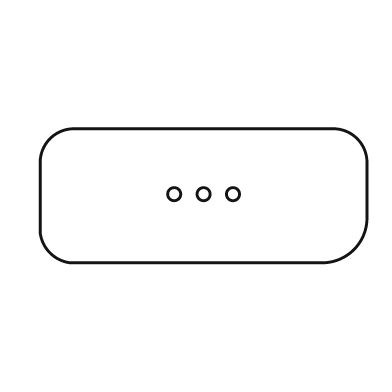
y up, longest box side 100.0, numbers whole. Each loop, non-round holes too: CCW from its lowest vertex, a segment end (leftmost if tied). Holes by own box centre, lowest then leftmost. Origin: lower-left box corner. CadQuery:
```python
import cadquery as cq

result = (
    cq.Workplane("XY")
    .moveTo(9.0, 0.0)
    .lineTo(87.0, 0.0)
    .threePointArc((96.0, 4.0), (100.0, 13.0))
    .lineTo(100.0, 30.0)
    .threePointArc((97.0, 38.0), (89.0, 41.0))
    .lineTo(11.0, 41.0)
    .threePointArc((3.0, 38.0), (0.0, 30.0))
    .lineTo(0.0, 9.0)
    .threePointArc((3.0, 3.0), (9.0, 0.0))
    .close()
    .moveTo(41.0, 21.0)
    .circle(2.0)
    .moveTo(50.0, 21.0)
    .circle(2.0)
    .moveTo(59.0, 21.0)
    .circle(2.0)
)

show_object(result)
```